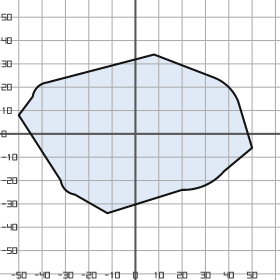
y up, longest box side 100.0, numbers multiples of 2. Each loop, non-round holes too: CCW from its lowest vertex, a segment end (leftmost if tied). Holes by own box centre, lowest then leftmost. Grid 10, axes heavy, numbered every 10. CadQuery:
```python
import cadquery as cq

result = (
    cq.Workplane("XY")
    .moveTo(-12.0, -34.0)
    .lineTo(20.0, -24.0)
    .threePointArc((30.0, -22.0), (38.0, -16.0))
    .lineTo(50.0, -6.0)
    .lineTo(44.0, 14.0)
    .threePointArc((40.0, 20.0), (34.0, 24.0))
    .lineTo(8.0, 34.0)
    .lineTo(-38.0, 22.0)
    .threePointArc((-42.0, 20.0), (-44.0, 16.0))
    .lineTo(-50.0, 8.0)
    .lineTo(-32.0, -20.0)
    .threePointArc((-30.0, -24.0), (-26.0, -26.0))
    .close()
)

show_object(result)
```